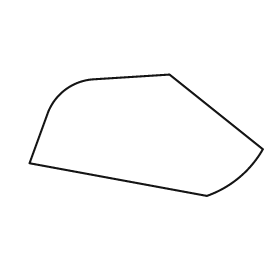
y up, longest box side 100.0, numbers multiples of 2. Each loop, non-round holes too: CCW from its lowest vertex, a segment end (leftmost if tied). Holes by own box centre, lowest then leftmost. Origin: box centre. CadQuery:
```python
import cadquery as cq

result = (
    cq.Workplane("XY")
    .moveTo(26.0, -26.0)
    .threePointArc((40.0, -18.0), (50.0, -6.0))
    .lineTo(10.0, 26.0)
    .lineTo(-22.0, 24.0)
    .threePointArc((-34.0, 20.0), (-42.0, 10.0))
    .lineTo(-50.0, -12.0)
    .close()
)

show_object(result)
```